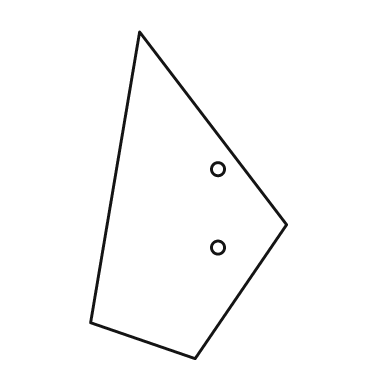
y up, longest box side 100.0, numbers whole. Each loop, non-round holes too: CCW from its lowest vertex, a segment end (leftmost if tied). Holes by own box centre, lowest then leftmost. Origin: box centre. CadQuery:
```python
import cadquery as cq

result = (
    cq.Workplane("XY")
    .moveTo(2.0, -50.0)
    .lineTo(30.0, -9.0)
    .lineTo(-15.0, 50.0)
    .lineTo(-30.0, -39.0)
    .close()
    .moveTo(9.0, -16.0)
    .circle(2.0)
    .moveTo(9.0, 8.0)
    .circle(2.0)
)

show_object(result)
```